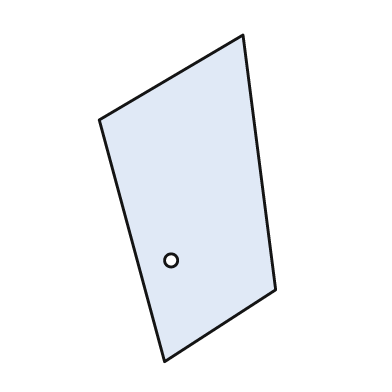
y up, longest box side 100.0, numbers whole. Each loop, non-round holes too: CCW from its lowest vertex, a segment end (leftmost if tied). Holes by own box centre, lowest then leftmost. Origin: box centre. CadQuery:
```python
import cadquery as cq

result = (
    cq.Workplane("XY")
    .moveTo(-7.0, -50.0)
    .lineTo(27.0, -28.0)
    .lineTo(17.0, 50.0)
    .lineTo(-27.0, 24.0)
    .close()
    .moveTo(-5.0, -19.0)
    .circle(2.0)
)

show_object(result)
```